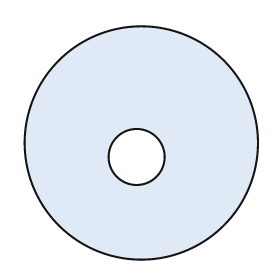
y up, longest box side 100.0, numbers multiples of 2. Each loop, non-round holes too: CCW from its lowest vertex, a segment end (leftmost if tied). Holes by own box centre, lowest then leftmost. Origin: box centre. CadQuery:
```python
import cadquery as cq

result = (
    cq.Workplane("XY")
    .moveTo(0.0, 0.0)
    .circle(50.0)
    .moveTo(-2.0, -6.0)
    .circle(12.0)
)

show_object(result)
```